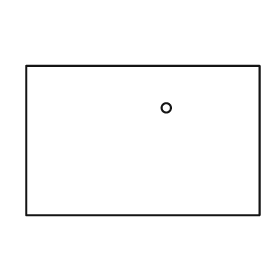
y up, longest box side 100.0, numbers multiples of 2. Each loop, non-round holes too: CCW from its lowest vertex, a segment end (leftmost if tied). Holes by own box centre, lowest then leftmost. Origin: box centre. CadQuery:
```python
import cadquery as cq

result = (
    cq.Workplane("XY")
    .moveTo(-50.0, -32.0)
    .lineTo(50.0, -32.0)
    .lineTo(50.0, 32.0)
    .lineTo(-50.0, 32.0)
    .close()
    .moveTo(10.0, 14.0)
    .circle(2.0)
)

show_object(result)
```